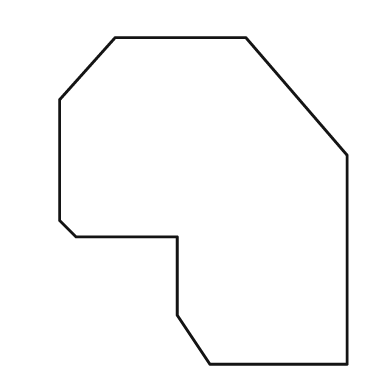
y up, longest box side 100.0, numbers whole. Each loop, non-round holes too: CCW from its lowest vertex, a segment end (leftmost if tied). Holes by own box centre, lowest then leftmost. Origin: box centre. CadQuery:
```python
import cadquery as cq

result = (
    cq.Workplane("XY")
    .moveTo(2.0, -50.0)
    .lineTo(44.0, -50.0)
    .lineTo(44.0, 14.0)
    .lineTo(13.0, 50.0)
    .lineTo(-27.0, 50.0)
    .lineTo(-44.0, 31.0)
    .lineTo(-44.0, -6.0)
    .lineTo(-39.0, -11.0)
    .lineTo(-8.0, -11.0)
    .lineTo(-8.0, -35.0)
    .close()
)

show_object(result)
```